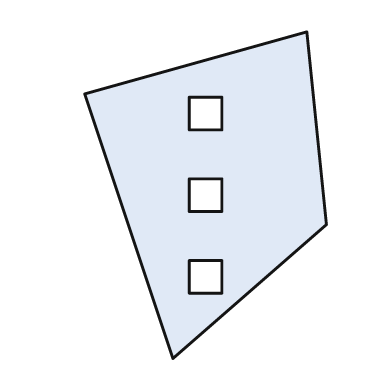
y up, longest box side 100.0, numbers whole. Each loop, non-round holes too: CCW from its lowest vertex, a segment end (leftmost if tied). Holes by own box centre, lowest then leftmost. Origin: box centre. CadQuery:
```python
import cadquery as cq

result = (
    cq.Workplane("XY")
    .moveTo(-10.0, -50.0)
    .lineTo(37.0, -9.0)
    .lineTo(31.0, 50.0)
    .lineTo(-37.0, 31.0)
    .close()
    .moveTo(-5.0, -30.0)
    .lineTo(5.0, -30.0)
    .lineTo(5.0, -20.0)
    .lineTo(-5.0, -20.0)
    .close()
    .moveTo(-5.0, -5.0)
    .lineTo(5.0, -5.0)
    .lineTo(5.0, 5.0)
    .lineTo(-5.0, 5.0)
    .close()
    .moveTo(-5.0, 20.0)
    .lineTo(5.0, 20.0)
    .lineTo(5.0, 30.0)
    .lineTo(-5.0, 30.0)
    .close()
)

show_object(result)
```